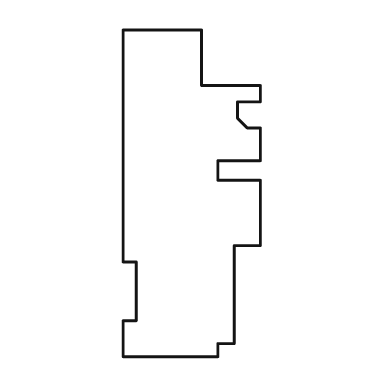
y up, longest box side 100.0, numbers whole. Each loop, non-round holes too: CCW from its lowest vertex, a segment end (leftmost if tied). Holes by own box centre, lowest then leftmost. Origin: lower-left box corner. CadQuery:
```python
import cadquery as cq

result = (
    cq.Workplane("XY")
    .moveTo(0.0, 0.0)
    .lineTo(29.0, 0.0)
    .lineTo(29.0, 4.0)
    .lineTo(34.0, 4.0)
    .lineTo(34.0, 34.0)
    .lineTo(42.0, 34.0)
    .lineTo(42.0, 54.0)
    .lineTo(29.0, 54.0)
    .lineTo(29.0, 60.0)
    .lineTo(42.0, 60.0)
    .lineTo(42.0, 70.0)
    .lineTo(38.0, 70.0)
    .lineTo(35.0, 73.0)
    .lineTo(35.0, 78.0)
    .lineTo(42.0, 78.0)
    .lineTo(42.0, 83.0)
    .lineTo(24.0, 83.0)
    .lineTo(24.0, 100.0)
    .lineTo(0.0, 100.0)
    .lineTo(0.0, 29.0)
    .lineTo(4.0, 29.0)
    .lineTo(4.0, 11.0)
    .lineTo(0.0, 11.0)
    .close()
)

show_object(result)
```